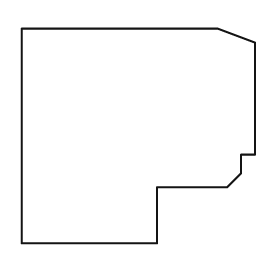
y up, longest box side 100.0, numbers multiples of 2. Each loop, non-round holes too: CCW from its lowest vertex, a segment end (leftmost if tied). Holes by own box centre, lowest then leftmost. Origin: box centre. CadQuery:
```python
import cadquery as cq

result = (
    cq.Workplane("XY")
    .moveTo(-50.0, -46.0)
    .lineTo(8.0, -46.0)
    .lineTo(8.0, -22.0)
    .lineTo(38.0, -22.0)
    .lineTo(44.0, -16.0)
    .lineTo(44.0, -8.0)
    .lineTo(50.0, -8.0)
    .lineTo(50.0, 40.0)
    .lineTo(34.0, 46.0)
    .lineTo(-50.0, 46.0)
    .close()
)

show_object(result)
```